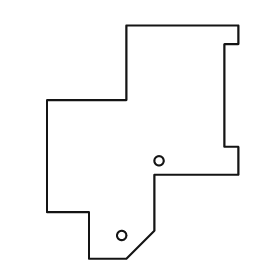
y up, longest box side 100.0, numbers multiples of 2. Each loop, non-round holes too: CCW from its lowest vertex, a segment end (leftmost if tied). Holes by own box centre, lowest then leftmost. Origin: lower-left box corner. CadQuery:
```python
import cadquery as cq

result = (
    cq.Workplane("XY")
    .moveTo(18.0, 0.0)
    .lineTo(34.0, 0.0)
    .lineTo(46.0, 12.0)
    .lineTo(46.0, 36.0)
    .lineTo(82.0, 36.0)
    .lineTo(82.0, 48.0)
    .lineTo(76.0, 48.0)
    .lineTo(76.0, 92.0)
    .lineTo(82.0, 92.0)
    .lineTo(82.0, 100.0)
    .lineTo(34.0, 100.0)
    .lineTo(34.0, 68.0)
    .lineTo(0.0, 68.0)
    .lineTo(0.0, 20.0)
    .lineTo(18.0, 20.0)
    .close()
    .moveTo(32.0, 10.0)
    .circle(2.0)
    .moveTo(48.0, 42.0)
    .circle(2.0)
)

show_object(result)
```